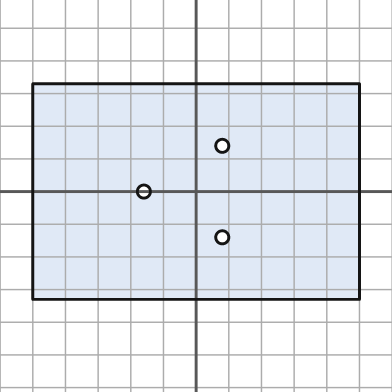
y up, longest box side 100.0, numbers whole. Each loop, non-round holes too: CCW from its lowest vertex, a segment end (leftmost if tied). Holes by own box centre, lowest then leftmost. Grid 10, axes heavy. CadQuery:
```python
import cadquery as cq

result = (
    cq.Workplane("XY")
    .moveTo(-50.0, -33.0)
    .lineTo(50.0, -33.0)
    .lineTo(50.0, 33.0)
    .lineTo(-50.0, 33.0)
    .close()
    .moveTo(8.0, -14.0)
    .circle(2.0)
    .moveTo(-16.0, 0.0)
    .circle(2.0)
    .moveTo(8.0, 14.0)
    .circle(2.0)
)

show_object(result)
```